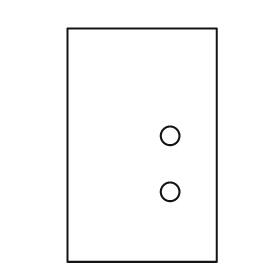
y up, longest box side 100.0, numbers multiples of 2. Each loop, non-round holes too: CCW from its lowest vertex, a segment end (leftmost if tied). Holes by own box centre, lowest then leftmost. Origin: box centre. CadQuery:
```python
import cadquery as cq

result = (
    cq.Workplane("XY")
    .moveTo(-32.0, -50.0)
    .lineTo(32.0, -50.0)
    .lineTo(32.0, 50.0)
    .lineTo(-32.0, 50.0)
    .close()
    .moveTo(12.0, -20.0)
    .circle(4.0)
    .moveTo(12.0, 4.0)
    .circle(4.0)
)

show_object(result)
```